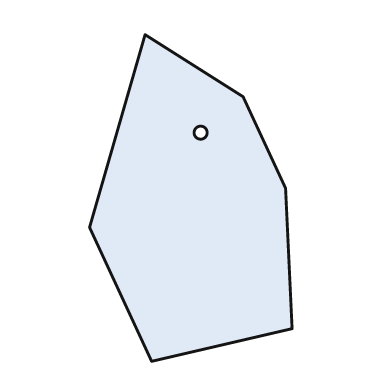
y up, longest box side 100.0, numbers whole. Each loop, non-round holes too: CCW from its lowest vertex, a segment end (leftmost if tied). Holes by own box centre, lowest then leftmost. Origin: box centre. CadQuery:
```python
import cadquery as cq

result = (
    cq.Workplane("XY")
    .moveTo(-12.0, -50.0)
    .lineTo(31.0, -40.0)
    .lineTo(29.0, 3.0)
    .lineTo(16.0, 31.0)
    .lineTo(-14.0, 50.0)
    .lineTo(-31.0, -9.0)
    .close()
    .moveTo(3.0, 20.0)
    .circle(2.0)
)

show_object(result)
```